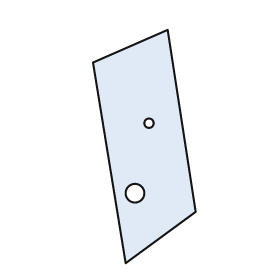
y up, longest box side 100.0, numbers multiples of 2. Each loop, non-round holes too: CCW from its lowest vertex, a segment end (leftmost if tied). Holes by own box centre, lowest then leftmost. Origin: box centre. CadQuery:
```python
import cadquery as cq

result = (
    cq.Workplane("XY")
    .moveTo(-8.0, -50.0)
    .lineTo(22.0, -28.0)
    .lineTo(10.0, 50.0)
    .lineTo(-22.0, 36.0)
    .close()
    .moveTo(-4.0, -20.0)
    .circle(4.0)
    .moveTo(2.0, 10.0)
    .circle(2.0)
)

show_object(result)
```